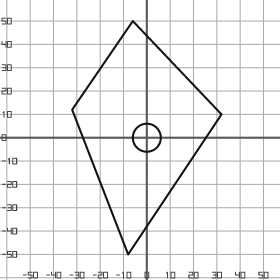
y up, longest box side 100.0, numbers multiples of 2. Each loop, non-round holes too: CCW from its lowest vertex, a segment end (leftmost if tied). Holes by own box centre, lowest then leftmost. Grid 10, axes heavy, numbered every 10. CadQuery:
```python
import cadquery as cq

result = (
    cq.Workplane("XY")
    .moveTo(-8.0, -50.0)
    .lineTo(32.0, 10.0)
    .lineTo(-6.0, 50.0)
    .lineTo(-32.0, 12.0)
    .close()
    .moveTo(0.0, 0.0)
    .circle(6.0)
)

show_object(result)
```